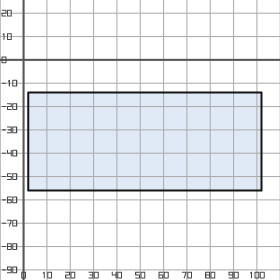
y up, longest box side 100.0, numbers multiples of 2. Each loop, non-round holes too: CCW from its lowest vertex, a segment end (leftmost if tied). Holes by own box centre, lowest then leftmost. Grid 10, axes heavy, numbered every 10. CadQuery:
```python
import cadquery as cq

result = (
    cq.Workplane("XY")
    .moveTo(2.0, -56.0)
    .lineTo(102.0, -56.0)
    .lineTo(102.0, -14.0)
    .lineTo(2.0, -14.0)
    .close()
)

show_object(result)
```